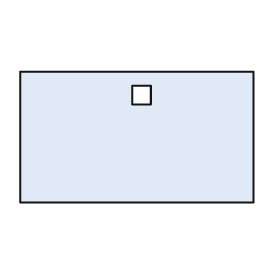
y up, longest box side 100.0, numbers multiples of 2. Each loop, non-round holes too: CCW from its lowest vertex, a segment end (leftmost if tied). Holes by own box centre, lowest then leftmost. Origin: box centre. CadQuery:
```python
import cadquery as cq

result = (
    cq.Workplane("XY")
    .moveTo(-50.0, -28.0)
    .lineTo(50.0, -28.0)
    .lineTo(50.0, 28.0)
    .lineTo(-50.0, 28.0)
    .close()
    .moveTo(-2.0, 14.0)
    .lineTo(6.0, 14.0)
    .lineTo(6.0, 22.0)
    .lineTo(-2.0, 22.0)
    .close()
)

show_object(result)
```